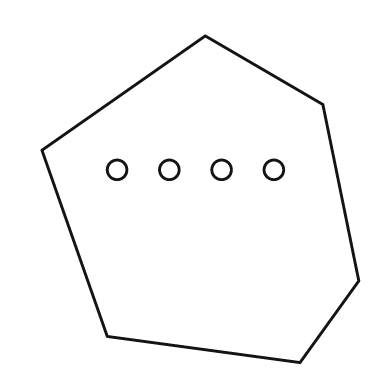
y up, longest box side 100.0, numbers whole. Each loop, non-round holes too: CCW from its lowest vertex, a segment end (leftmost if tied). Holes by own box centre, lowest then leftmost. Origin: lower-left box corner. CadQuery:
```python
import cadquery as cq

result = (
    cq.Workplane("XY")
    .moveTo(79.0, 0.0)
    .lineTo(97.0, 25.0)
    .lineTo(86.0, 79.0)
    .lineTo(50.0, 100.0)
    .lineTo(0.0, 65.0)
    .lineTo(20.0, 8.0)
    .close()
    .moveTo(23.0, 59.0)
    .circle(3.0)
    .moveTo(39.0, 59.0)
    .circle(3.0)
    .moveTo(55.0, 59.0)
    .circle(3.0)
    .moveTo(71.0, 59.0)
    .circle(3.0)
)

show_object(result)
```